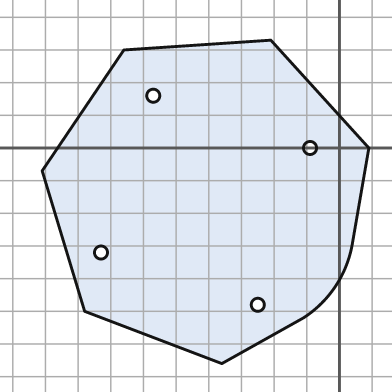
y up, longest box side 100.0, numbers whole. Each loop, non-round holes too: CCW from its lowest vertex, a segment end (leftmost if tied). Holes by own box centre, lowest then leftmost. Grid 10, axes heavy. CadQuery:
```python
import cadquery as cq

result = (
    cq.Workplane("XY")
    .moveTo(-36.0, -66.0)
    .lineTo(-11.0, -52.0)
    .threePointArc((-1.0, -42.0), (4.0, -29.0))
    .lineTo(9.0, 0.0)
    .lineTo(-21.0, 33.0)
    .lineTo(-66.0, 30.0)
    .lineTo(-91.0, -7.0)
    .lineTo(-78.0, -50.0)
    .close()
    .moveTo(-25.0, -48.0)
    .circle(2.0)
    .moveTo(-73.0, -32.0)
    .circle(2.0)
    .moveTo(-9.0, 0.0)
    .circle(2.0)
    .moveTo(-57.0, 16.0)
    .circle(2.0)
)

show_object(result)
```